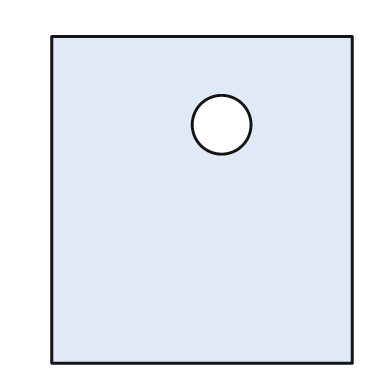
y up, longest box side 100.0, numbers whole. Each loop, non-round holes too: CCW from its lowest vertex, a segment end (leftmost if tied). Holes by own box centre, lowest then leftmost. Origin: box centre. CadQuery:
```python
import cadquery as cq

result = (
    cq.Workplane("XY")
    .moveTo(-46.0, -50.0)
    .lineTo(46.0, -50.0)
    .lineTo(46.0, 50.0)
    .lineTo(-46.0, 50.0)
    .close()
    .moveTo(6.0, 23.0)
    .circle(9.0)
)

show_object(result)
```